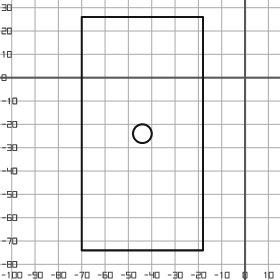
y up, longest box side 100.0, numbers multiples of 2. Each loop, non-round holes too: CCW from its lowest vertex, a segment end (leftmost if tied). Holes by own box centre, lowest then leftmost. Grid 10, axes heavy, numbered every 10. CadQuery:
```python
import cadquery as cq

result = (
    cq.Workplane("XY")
    .moveTo(-70.0, -74.0)
    .lineTo(-18.0, -74.0)
    .lineTo(-18.0, 26.0)
    .lineTo(-70.0, 26.0)
    .close()
    .moveTo(-44.0, -24.0)
    .circle(4.0)
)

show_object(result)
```